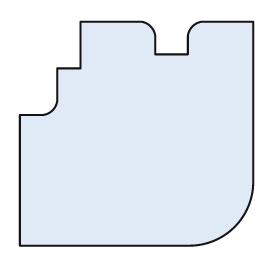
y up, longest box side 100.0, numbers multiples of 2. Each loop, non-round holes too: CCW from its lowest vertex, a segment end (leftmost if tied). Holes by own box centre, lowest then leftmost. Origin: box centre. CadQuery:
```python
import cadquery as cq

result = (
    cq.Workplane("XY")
    .moveTo(-50.0, -48.0)
    .lineTo(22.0, -48.0)
    .threePointArc((42.0, -40.0), (50.0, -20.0))
    .lineTo(50.0, 48.0)
    .lineTo(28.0, 48.0)
    .threePointArc((24.0, 46.0), (22.0, 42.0))
    .lineTo(22.0, 34.0)
    .lineTo(8.0, 34.0)
    .lineTo(8.0, 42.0)
    .threePointArc((6.0, 46.0), (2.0, 48.0))
    .lineTo(-24.0, 48.0)
    .lineTo(-24.0, 28.0)
    .lineTo(-34.0, 28.0)
    .lineTo(-34.0, 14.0)
    .threePointArc((-36.0, 10.0), (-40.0, 8.0))
    .lineTo(-50.0, 8.0)
    .close()
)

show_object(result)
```